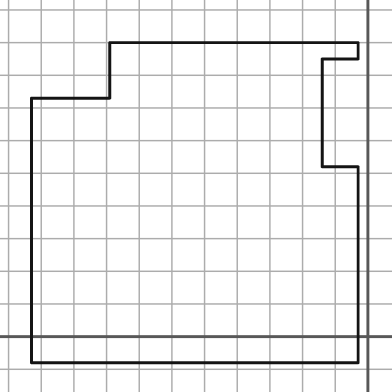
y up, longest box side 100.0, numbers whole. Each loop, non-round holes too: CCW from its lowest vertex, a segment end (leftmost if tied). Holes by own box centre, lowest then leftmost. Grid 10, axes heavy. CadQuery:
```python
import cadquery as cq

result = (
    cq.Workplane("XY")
    .moveTo(-103.0, -8.0)
    .lineTo(-3.0, -8.0)
    .lineTo(-3.0, 52.0)
    .lineTo(-14.0, 52.0)
    .lineTo(-14.0, 85.0)
    .lineTo(-3.0, 85.0)
    .lineTo(-3.0, 90.0)
    .lineTo(-79.0, 90.0)
    .lineTo(-79.0, 73.0)
    .lineTo(-103.0, 73.0)
    .close()
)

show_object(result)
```